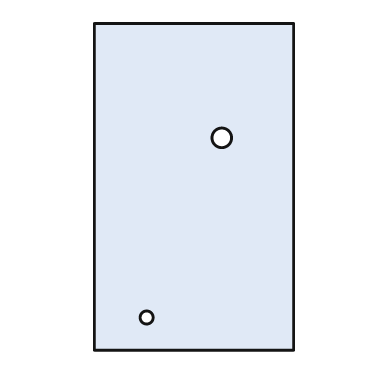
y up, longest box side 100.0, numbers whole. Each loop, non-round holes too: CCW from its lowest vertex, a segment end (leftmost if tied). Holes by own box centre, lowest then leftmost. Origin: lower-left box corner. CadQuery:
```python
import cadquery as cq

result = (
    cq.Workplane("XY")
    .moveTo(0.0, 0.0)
    .lineTo(61.0, 0.0)
    .lineTo(61.0, 100.0)
    .lineTo(0.0, 100.0)
    .close()
    .moveTo(16.0, 10.0)
    .circle(2.0)
    .moveTo(39.0, 65.0)
    .circle(3.0)
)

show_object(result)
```